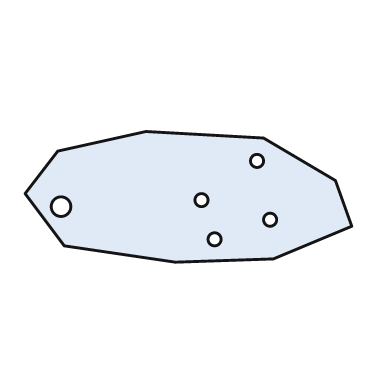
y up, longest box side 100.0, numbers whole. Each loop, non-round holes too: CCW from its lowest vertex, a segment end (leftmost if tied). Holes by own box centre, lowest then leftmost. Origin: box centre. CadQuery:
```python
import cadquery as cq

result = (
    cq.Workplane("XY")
    .moveTo(-4.0, -20.0)
    .lineTo(26.0, -19.0)
    .lineTo(50.0, -9.0)
    .lineTo(45.0, 5.0)
    .lineTo(23.0, 18.0)
    .lineTo(-13.0, 20.0)
    .lineTo(-40.0, 14.0)
    .lineTo(-50.0, 1.0)
    .lineTo(-38.0, -15.0)
    .close()
    .moveTo(8.0, -13.0)
    .circle(2.0)
    .moveTo(25.0, -7.0)
    .circle(2.0)
    .moveTo(-39.0, -3.0)
    .circle(3.0)
    .moveTo(4.0, -1.0)
    .circle(2.0)
    .moveTo(21.0, 11.0)
    .circle(2.0)
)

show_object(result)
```